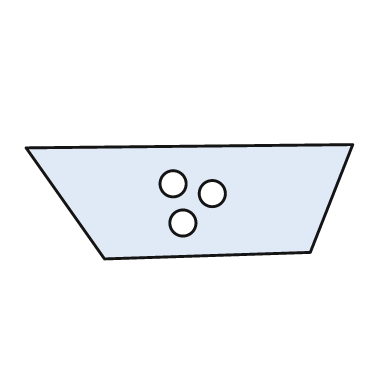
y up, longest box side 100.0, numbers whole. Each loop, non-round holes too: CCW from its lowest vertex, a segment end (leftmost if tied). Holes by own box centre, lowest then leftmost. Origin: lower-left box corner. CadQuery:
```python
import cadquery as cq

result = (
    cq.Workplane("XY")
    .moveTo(24.0, 0.0)
    .lineTo(87.0, 2.0)
    .lineTo(100.0, 35.0)
    .lineTo(0.0, 34.0)
    .close()
    .moveTo(48.0, 11.0)
    .circle(4.0)
    .moveTo(57.0, 20.0)
    .circle(4.0)
    .moveTo(45.0, 23.0)
    .circle(4.0)
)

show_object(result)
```